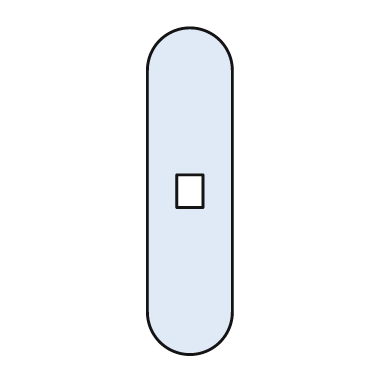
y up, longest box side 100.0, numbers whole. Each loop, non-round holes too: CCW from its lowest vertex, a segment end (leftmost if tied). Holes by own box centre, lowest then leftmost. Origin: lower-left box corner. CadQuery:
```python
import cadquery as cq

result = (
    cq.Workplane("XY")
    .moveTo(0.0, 13.0)
    .threePointArc((13.0, 0.0), (26.0, 13.0))
    .lineTo(26.0, 87.0)
    .threePointArc((13.0, 100.0), (0.0, 87.0))
    .close()
    .moveTo(9.0, 45.0)
    .lineTo(17.0, 45.0)
    .lineTo(17.0, 55.0)
    .lineTo(9.0, 55.0)
    .close()
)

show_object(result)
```